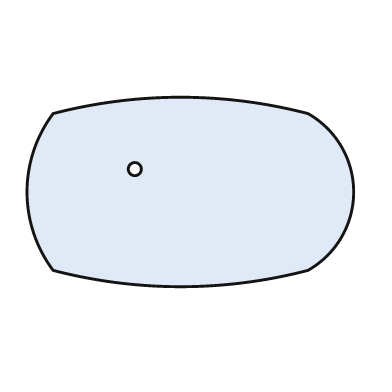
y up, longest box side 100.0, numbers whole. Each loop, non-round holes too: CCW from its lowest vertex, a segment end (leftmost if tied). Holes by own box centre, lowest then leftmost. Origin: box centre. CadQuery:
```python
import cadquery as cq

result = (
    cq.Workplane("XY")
    .moveTo(-42.0, -24.0)
    .threePointArc((-3.0, -29.0), (36.0, -24.0))
    .threePointArc((50.0, 0.0), (36.0, 24.0))
    .threePointArc((-3.0, 29.0), (-42.0, 24.0))
    .threePointArc((-50.0, 0.0), (-42.0, -24.0))
    .close()
    .moveTo(-17.0, 7.0)
    .circle(2.0)
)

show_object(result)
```